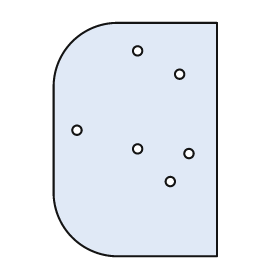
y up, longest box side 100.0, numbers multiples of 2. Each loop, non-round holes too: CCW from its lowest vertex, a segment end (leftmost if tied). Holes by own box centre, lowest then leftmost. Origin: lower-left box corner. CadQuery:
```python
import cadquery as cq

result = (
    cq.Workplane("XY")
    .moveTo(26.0, 0.0)
    .lineTo(70.0, 0.0)
    .lineTo(70.0, 100.0)
    .lineTo(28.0, 100.0)
    .threePointArc((8.0, 92.0), (0.0, 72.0))
    .lineTo(0.0, 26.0)
    .threePointArc((8.0, 8.0), (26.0, 0.0))
    .close()
    .moveTo(50.0, 32.0)
    .circle(2.0)
    .moveTo(58.0, 44.0)
    .circle(2.0)
    .moveTo(36.0, 46.0)
    .circle(2.0)
    .moveTo(10.0, 54.0)
    .circle(2.0)
    .moveTo(54.0, 78.0)
    .circle(2.0)
    .moveTo(36.0, 88.0)
    .circle(2.0)
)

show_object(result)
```